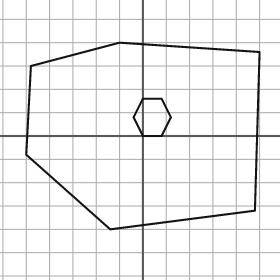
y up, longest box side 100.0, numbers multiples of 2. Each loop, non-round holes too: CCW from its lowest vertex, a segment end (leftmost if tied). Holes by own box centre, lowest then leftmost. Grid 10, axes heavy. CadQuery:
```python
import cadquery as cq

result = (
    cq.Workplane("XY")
    .moveTo(-14.0, -40.0)
    .lineTo(48.0, -32.0)
    .lineTo(50.0, 36.0)
    .lineTo(-10.0, 40.0)
    .lineTo(-48.0, 30.0)
    .lineTo(-50.0, -8.0)
    .close()
    .moveTo(0.0, 0.0)
    .lineTo(8.0, 0.0)
    .lineTo(12.0, 8.0)
    .lineTo(8.0, 16.0)
    .lineTo(0.0, 16.0)
    .lineTo(-4.0, 8.0)
    .close()
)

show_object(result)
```